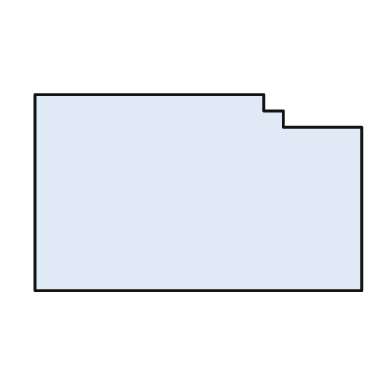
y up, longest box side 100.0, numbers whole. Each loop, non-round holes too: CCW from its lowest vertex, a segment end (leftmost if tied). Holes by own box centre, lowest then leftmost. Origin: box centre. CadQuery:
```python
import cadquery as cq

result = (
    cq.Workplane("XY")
    .moveTo(-50.0, -30.0)
    .lineTo(50.0, -30.0)
    .lineTo(50.0, 20.0)
    .lineTo(26.0, 20.0)
    .lineTo(26.0, 25.0)
    .lineTo(20.0, 25.0)
    .lineTo(20.0, 30.0)
    .lineTo(-50.0, 30.0)
    .close()
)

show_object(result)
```